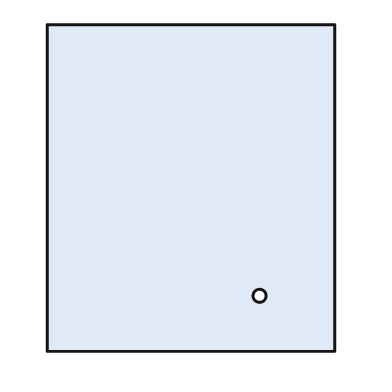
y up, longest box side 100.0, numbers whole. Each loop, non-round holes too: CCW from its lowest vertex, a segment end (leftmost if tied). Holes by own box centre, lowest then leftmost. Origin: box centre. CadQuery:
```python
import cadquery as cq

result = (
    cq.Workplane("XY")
    .moveTo(-44.0, -50.0)
    .lineTo(44.0, -50.0)
    .lineTo(44.0, 50.0)
    .lineTo(-44.0, 50.0)
    .close()
    .moveTo(21.0, -33.0)
    .circle(2.0)
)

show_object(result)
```